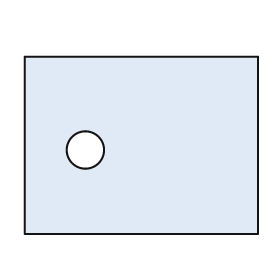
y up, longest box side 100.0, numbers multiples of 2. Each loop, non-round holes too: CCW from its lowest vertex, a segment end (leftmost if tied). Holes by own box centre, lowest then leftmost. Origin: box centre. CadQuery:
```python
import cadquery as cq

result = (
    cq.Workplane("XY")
    .moveTo(-50.0, -38.0)
    .lineTo(50.0, -38.0)
    .lineTo(50.0, 38.0)
    .lineTo(-50.0, 38.0)
    .close()
    .moveTo(-24.0, -2.0)
    .circle(8.0)
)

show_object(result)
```